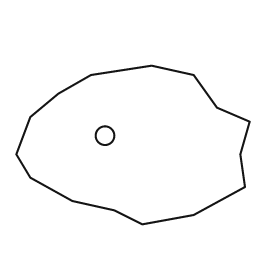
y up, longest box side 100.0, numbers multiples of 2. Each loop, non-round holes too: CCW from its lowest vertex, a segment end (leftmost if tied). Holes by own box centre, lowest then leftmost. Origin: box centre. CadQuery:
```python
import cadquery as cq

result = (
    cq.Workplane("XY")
    .moveTo(4.0, -34.0)
    .lineTo(26.0, -30.0)
    .lineTo(48.0, -18.0)
    .lineTo(46.0, -4.0)
    .lineTo(50.0, 10.0)
    .lineTo(36.0, 16.0)
    .lineTo(26.0, 30.0)
    .lineTo(8.0, 34.0)
    .lineTo(-18.0, 30.0)
    .lineTo(-32.0, 22.0)
    .lineTo(-44.0, 12.0)
    .lineTo(-50.0, -4.0)
    .lineTo(-44.0, -14.0)
    .lineTo(-26.0, -24.0)
    .lineTo(-8.0, -28.0)
    .close()
    .moveTo(-12.0, 4.0)
    .circle(4.0)
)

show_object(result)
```